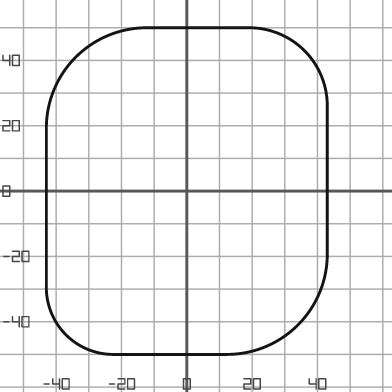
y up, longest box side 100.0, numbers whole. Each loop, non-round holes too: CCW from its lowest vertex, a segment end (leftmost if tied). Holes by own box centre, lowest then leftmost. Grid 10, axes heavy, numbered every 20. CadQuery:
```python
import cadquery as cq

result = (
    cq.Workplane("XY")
    .moveTo(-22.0, -50.0)
    .lineTo(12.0, -50.0)
    .threePointArc((34.0, -41.0), (43.0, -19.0))
    .lineTo(43.0, 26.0)
    .threePointArc((36.0, 43.0), (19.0, 50.0))
    .lineTo(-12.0, 50.0)
    .threePointArc((-34.0, 41.0), (-43.0, 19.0))
    .lineTo(-43.0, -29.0)
    .threePointArc((-37.0, -44.0), (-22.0, -50.0))
    .close()
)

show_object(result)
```